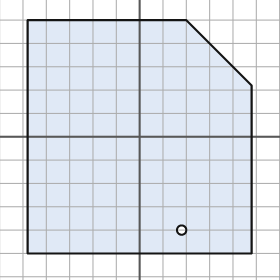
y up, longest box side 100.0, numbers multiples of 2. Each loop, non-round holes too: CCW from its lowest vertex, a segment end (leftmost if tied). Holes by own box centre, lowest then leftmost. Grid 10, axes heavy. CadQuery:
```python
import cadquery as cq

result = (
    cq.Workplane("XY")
    .moveTo(-48.0, -50.0)
    .lineTo(48.0, -50.0)
    .lineTo(48.0, 22.0)
    .lineTo(20.0, 50.0)
    .lineTo(-48.0, 50.0)
    .close()
    .moveTo(18.0, -40.0)
    .circle(2.0)
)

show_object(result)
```